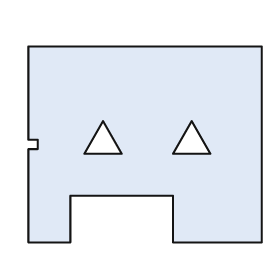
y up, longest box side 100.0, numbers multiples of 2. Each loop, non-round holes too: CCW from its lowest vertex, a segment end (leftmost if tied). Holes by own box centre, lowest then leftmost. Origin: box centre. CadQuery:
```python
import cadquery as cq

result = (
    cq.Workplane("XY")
    .moveTo(-50.0, -42.0)
    .lineTo(-32.0, -42.0)
    .lineTo(-32.0, -22.0)
    .lineTo(12.0, -22.0)
    .lineTo(12.0, -42.0)
    .lineTo(50.0, -42.0)
    .lineTo(50.0, 42.0)
    .lineTo(-50.0, 42.0)
    .lineTo(-50.0, 2.0)
    .lineTo(-46.0, 2.0)
    .lineTo(-46.0, -2.0)
    .lineTo(-50.0, -2.0)
    .close()
    .moveTo(-26.0, -4.0)
    .lineTo(-10.0, -4.0)
    .lineTo(-18.0, 10.0)
    .close()
    .moveTo(12.0, -4.0)
    .lineTo(28.0, -4.0)
    .lineTo(20.0, 10.0)
    .close()
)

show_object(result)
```